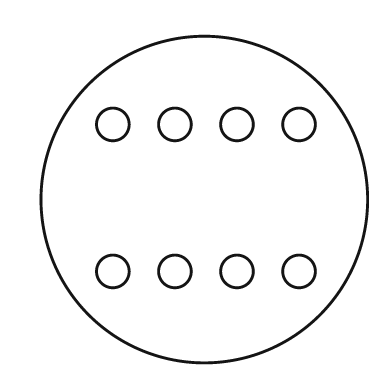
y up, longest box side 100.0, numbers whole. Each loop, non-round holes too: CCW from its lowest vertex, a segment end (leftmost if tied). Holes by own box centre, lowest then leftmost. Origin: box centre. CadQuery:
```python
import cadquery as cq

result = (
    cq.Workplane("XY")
    .moveTo(0.0, 0.0)
    .circle(50.0)
    .moveTo(-28.0, -22.0)
    .circle(5.0)
    .moveTo(-9.0, -22.0)
    .circle(5.0)
    .moveTo(10.0, -22.0)
    .circle(5.0)
    .moveTo(29.0, -22.0)
    .circle(5.0)
    .moveTo(-28.0, 23.0)
    .circle(5.0)
    .moveTo(-9.0, 23.0)
    .circle(5.0)
    .moveTo(10.0, 23.0)
    .circle(5.0)
    .moveTo(29.0, 23.0)
    .circle(5.0)
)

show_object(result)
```